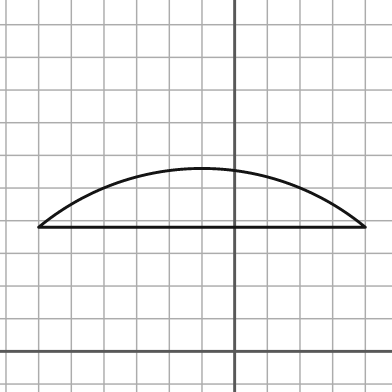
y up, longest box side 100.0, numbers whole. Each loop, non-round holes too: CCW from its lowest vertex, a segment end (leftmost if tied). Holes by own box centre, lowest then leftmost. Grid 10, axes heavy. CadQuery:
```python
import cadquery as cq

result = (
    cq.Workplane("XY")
    .moveTo(-60.0, 38.0)
    .lineTo(40.0, 38.0)
    .threePointArc((-10.0, 56.0), (-60.0, 38.0))
    .close()
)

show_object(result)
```